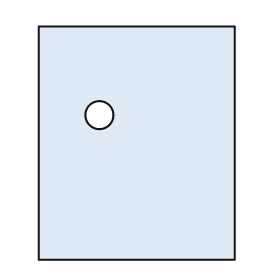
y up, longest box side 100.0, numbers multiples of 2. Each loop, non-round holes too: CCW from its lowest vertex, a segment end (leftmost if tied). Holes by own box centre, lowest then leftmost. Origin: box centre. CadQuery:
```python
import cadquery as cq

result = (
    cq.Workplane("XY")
    .moveTo(-42.0, -50.0)
    .lineTo(42.0, -50.0)
    .lineTo(42.0, 50.0)
    .lineTo(-42.0, 50.0)
    .close()
    .moveTo(-16.0, 12.0)
    .circle(6.0)
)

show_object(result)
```